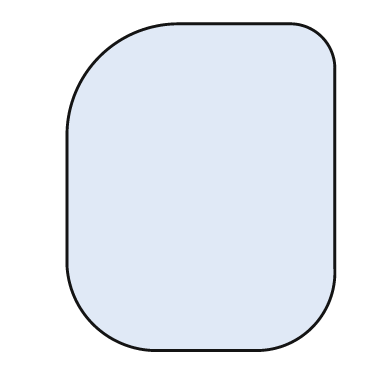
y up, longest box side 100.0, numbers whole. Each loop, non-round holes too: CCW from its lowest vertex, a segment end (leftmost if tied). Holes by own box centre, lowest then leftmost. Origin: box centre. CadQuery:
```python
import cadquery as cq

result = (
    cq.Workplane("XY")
    .moveTo(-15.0, -50.0)
    .lineTo(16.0, -50.0)
    .threePointArc((34.0, -43.0), (41.0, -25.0))
    .lineTo(41.0, 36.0)
    .threePointArc((37.0, 46.0), (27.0, 50.0))
    .lineTo(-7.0, 50.0)
    .threePointArc((-31.0, 40.0), (-41.0, 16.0))
    .lineTo(-41.0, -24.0)
    .threePointArc((-33.0, -42.0), (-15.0, -50.0))
    .close()
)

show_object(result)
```